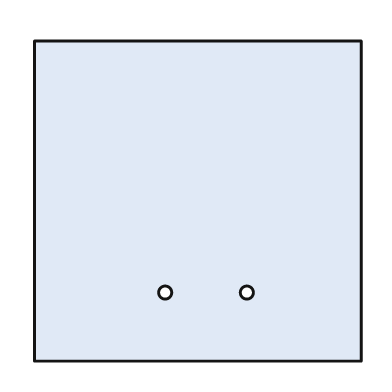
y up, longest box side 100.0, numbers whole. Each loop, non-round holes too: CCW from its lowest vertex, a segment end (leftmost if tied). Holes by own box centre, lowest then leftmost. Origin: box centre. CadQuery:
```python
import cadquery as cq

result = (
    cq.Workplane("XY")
    .moveTo(-50.0, -49.0)
    .lineTo(50.0, -49.0)
    .lineTo(50.0, 49.0)
    .lineTo(-50.0, 49.0)
    .close()
    .moveTo(-10.0, -28.0)
    .circle(2.0)
    .moveTo(15.0, -28.0)
    .circle(2.0)
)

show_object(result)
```